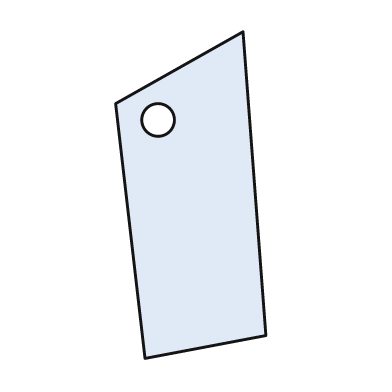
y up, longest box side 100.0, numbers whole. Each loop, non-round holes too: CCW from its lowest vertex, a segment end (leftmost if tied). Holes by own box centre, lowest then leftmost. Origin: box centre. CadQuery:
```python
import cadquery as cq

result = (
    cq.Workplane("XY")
    .moveTo(-14.0, -50.0)
    .lineTo(23.0, -43.0)
    .lineTo(16.0, 50.0)
    .lineTo(-23.0, 28.0)
    .close()
    .moveTo(-10.0, 23.0)
    .circle(5.0)
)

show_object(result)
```